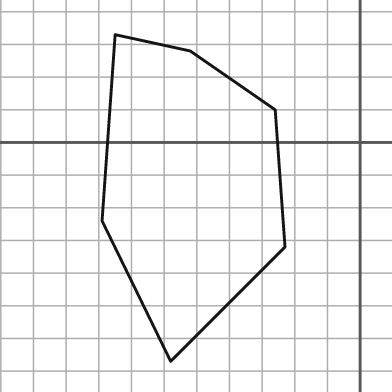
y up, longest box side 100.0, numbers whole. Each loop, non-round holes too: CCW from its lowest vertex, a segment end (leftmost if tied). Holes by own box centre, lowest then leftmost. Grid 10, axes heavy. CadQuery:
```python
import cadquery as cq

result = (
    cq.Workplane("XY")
    .moveTo(-58.0, -67.0)
    .lineTo(-23.0, -32.0)
    .lineTo(-26.0, 10.0)
    .lineTo(-52.0, 28.0)
    .lineTo(-75.0, 33.0)
    .lineTo(-79.0, -24.0)
    .close()
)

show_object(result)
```